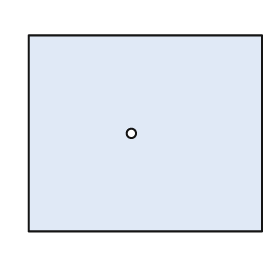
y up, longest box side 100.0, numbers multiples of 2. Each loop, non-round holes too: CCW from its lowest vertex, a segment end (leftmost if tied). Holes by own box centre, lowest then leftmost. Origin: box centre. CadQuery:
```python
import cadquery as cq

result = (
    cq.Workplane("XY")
    .moveTo(-50.0, -42.0)
    .lineTo(50.0, -42.0)
    .lineTo(50.0, 42.0)
    .lineTo(-50.0, 42.0)
    .close()
    .moveTo(-6.0, 0.0)
    .circle(2.0)
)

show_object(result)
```